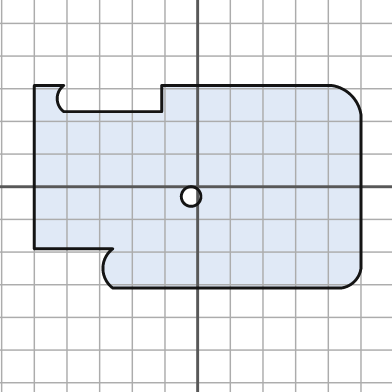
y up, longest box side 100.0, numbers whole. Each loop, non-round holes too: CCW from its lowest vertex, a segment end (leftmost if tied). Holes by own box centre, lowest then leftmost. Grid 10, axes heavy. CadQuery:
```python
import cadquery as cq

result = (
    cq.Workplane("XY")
    .moveTo(-26.0, -31.0)
    .lineTo(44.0, -31.0)
    .threePointArc((48.0, -29.0), (50.0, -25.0))
    .lineTo(50.0, 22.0)
    .threePointArc((47.0, 28.0), (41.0, 31.0))
    .lineTo(-11.0, 31.0)
    .lineTo(-11.0, 23.0)
    .lineTo(-41.0, 23.0)
    .threePointArc((-43.0, 27.0), (-41.0, 31.0))
    .lineTo(-50.0, 31.0)
    .lineTo(-50.0, -19.0)
    .lineTo(-26.0, -19.0)
    .threePointArc((-29.0, -25.0), (-26.0, -31.0))
    .close()
    .moveTo(-2.0, -3.0)
    .circle(3.0)
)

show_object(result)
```